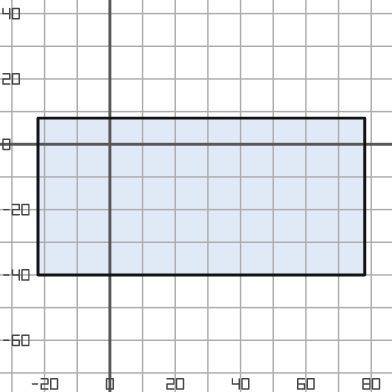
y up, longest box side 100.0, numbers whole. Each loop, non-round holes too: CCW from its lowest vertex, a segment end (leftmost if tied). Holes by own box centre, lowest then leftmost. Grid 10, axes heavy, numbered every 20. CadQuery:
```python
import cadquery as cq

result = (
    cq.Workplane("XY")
    .moveTo(-22.0, -40.0)
    .lineTo(78.0, -40.0)
    .lineTo(78.0, 8.0)
    .lineTo(-22.0, 8.0)
    .close()
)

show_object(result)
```